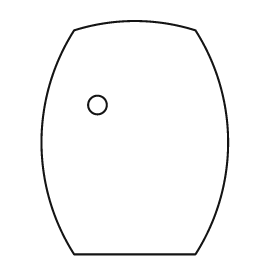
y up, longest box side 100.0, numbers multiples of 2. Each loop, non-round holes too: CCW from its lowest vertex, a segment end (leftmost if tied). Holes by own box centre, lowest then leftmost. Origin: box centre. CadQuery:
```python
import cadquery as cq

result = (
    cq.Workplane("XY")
    .moveTo(-26.0, -50.0)
    .lineTo(26.0, -50.0)
    .threePointArc((40.0, -2.0), (26.0, 46.0))
    .threePointArc((0.0, 50.0), (-26.0, 46.0))
    .threePointArc((-40.0, -2.0), (-26.0, -50.0))
    .close()
    .moveTo(-16.0, 14.0)
    .circle(4.0)
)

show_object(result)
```